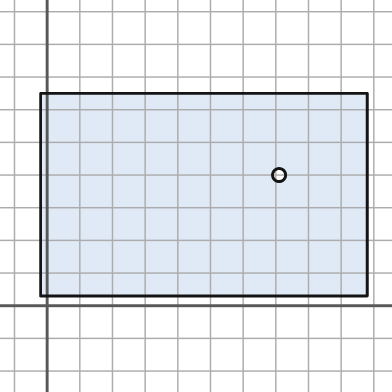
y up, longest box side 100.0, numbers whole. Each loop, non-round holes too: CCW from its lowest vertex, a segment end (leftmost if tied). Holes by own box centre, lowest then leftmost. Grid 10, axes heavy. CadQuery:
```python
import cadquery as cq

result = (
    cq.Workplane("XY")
    .moveTo(-2.0, 3.0)
    .lineTo(98.0, 3.0)
    .lineTo(98.0, 65.0)
    .lineTo(-2.0, 65.0)
    .close()
    .moveTo(71.0, 40.0)
    .circle(2.0)
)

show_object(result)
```